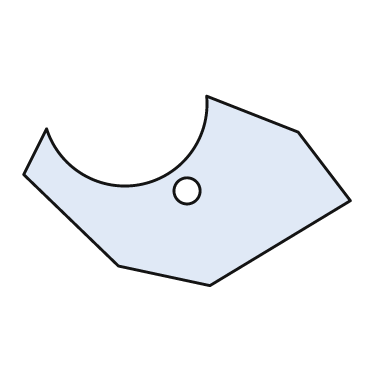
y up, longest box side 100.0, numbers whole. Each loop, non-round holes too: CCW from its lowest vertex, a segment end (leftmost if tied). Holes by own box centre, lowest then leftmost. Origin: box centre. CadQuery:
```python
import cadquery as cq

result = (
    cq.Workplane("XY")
    .moveTo(7.0, -29.0)
    .lineTo(50.0, -3.0)
    .lineTo(34.0, 18.0)
    .lineTo(6.0, 29.0)
    .threePointArc((-14.0, 2.0), (-43.0, 19.0))
    .lineTo(-50.0, 5.0)
    .lineTo(-21.0, -23.0)
    .close()
    .moveTo(0.0, 0.0)
    .circle(4.0)
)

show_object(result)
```